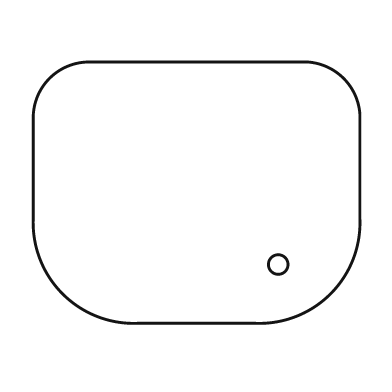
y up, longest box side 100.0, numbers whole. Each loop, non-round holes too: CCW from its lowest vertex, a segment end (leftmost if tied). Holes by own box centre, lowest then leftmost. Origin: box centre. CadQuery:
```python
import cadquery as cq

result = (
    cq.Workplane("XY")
    .moveTo(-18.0, -40.0)
    .lineTo(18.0, -40.0)
    .threePointArc((41.0, -31.0), (50.0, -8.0))
    .lineTo(50.0, 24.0)
    .threePointArc((45.0, 35.0), (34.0, 40.0))
    .lineTo(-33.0, 40.0)
    .threePointArc((-45.0, 35.0), (-50.0, 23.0))
    .lineTo(-50.0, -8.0)
    .threePointArc((-41.0, -31.0), (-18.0, -40.0))
    .close()
    .moveTo(25.0, -22.0)
    .circle(3.0)
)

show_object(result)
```